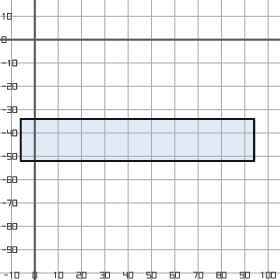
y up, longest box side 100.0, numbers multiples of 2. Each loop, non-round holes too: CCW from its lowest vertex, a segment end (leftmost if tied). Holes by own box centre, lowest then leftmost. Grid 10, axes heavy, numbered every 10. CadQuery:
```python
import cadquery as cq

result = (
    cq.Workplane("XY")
    .moveTo(-6.0, -52.0)
    .lineTo(94.0, -52.0)
    .lineTo(94.0, -34.0)
    .lineTo(-6.0, -34.0)
    .close()
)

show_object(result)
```